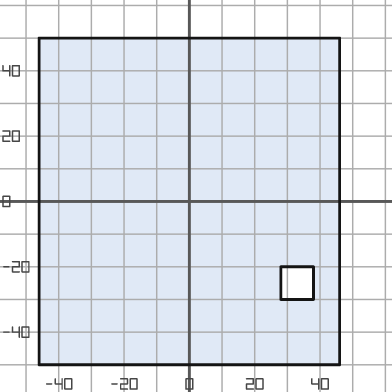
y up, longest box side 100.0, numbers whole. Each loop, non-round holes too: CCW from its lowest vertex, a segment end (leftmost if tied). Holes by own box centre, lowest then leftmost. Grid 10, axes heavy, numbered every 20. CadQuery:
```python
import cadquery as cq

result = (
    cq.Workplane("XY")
    .moveTo(-46.0, -50.0)
    .lineTo(46.0, -50.0)
    .lineTo(46.0, 50.0)
    .lineTo(-46.0, 50.0)
    .close()
    .moveTo(28.0, -30.0)
    .lineTo(38.0, -30.0)
    .lineTo(38.0, -20.0)
    .lineTo(28.0, -20.0)
    .close()
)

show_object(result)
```